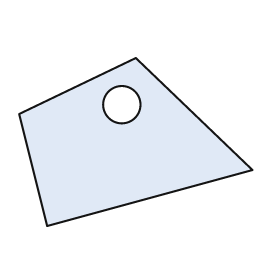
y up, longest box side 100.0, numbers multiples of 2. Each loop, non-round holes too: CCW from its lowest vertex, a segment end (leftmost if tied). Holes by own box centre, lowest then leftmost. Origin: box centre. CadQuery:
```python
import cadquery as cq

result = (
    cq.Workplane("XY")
    .moveTo(-38.0, -36.0)
    .lineTo(50.0, -12.0)
    .lineTo(0.0, 36.0)
    .lineTo(-50.0, 12.0)
    .close()
    .moveTo(-6.0, 16.0)
    .circle(8.0)
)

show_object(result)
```